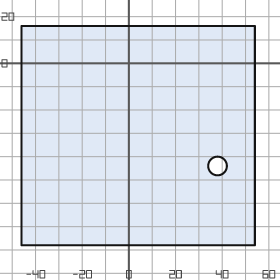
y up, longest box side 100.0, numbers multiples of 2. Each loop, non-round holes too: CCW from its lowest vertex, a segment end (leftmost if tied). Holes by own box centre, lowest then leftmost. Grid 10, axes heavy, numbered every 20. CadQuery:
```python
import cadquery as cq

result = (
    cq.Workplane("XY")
    .moveTo(-46.0, -78.0)
    .lineTo(54.0, -78.0)
    .lineTo(54.0, 16.0)
    .lineTo(-46.0, 16.0)
    .close()
    .moveTo(38.0, -44.0)
    .circle(4.0)
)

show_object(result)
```